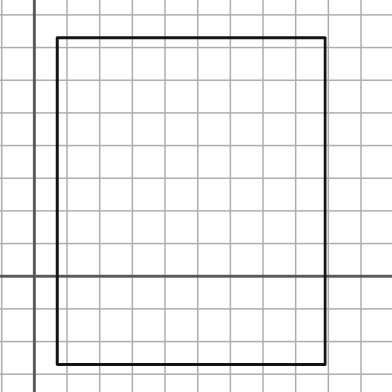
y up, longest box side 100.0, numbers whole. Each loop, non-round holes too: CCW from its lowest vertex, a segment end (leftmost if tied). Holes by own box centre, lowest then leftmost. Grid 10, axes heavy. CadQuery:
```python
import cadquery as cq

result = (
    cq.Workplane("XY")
    .moveTo(7.0, -27.0)
    .lineTo(89.0, -27.0)
    .lineTo(89.0, 73.0)
    .lineTo(7.0, 73.0)
    .close()
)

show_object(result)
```